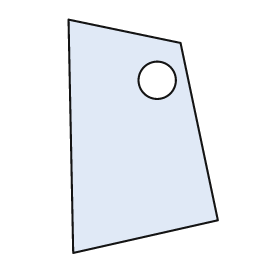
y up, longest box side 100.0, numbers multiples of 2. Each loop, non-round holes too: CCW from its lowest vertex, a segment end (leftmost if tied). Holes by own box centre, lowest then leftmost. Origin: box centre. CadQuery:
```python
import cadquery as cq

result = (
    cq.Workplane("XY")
    .moveTo(-30.0, -50.0)
    .lineTo(32.0, -36.0)
    .lineTo(16.0, 40.0)
    .lineTo(-32.0, 50.0)
    .close()
    .moveTo(6.0, 24.0)
    .circle(8.0)
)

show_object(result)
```